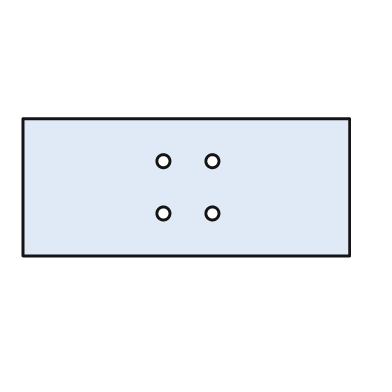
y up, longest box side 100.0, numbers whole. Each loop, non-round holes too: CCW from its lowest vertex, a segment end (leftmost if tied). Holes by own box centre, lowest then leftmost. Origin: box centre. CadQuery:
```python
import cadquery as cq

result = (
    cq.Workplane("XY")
    .moveTo(-50.0, -21.0)
    .lineTo(50.0, -21.0)
    .lineTo(50.0, 21.0)
    .lineTo(-50.0, 21.0)
    .close()
    .moveTo(-7.0, -8.0)
    .circle(2.0)
    .moveTo(8.0, -8.0)
    .circle(2.0)
    .moveTo(-7.0, 8.0)
    .circle(2.0)
    .moveTo(8.0, 8.0)
    .circle(2.0)
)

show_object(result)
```